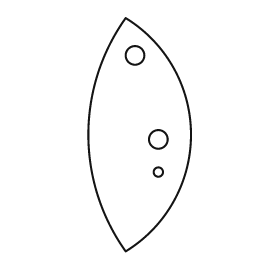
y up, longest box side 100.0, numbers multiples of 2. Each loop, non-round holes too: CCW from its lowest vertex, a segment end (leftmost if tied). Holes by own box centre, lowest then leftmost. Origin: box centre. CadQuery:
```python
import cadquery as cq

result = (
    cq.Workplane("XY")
    .moveTo(-6.0, -50.0)
    .threePointArc((22.0, 0.0), (-6.0, 50.0))
    .threePointArc((-22.0, 0.0), (-6.0, -50.0))
    .close()
    .moveTo(8.0, -16.0)
    .circle(2.0)
    .moveTo(8.0, -2.0)
    .circle(4.0)
    .moveTo(-2.0, 34.0)
    .circle(4.0)
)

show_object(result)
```